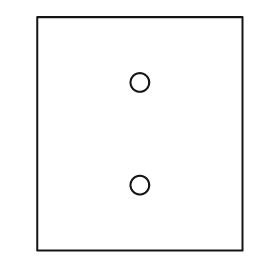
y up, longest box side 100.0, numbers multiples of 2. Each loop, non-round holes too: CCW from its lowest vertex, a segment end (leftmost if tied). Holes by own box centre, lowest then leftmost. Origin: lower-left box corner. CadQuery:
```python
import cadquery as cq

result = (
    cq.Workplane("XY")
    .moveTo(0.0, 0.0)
    .lineTo(88.0, 0.0)
    .lineTo(88.0, 100.0)
    .lineTo(0.0, 100.0)
    .close()
    .moveTo(44.0, 28.0)
    .circle(4.0)
    .moveTo(44.0, 72.0)
    .circle(4.0)
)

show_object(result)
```